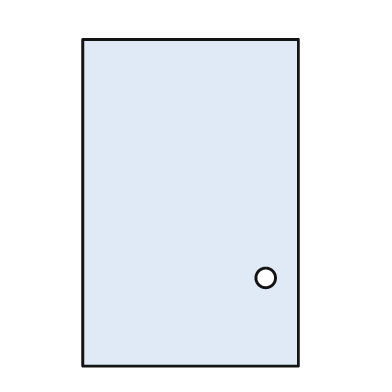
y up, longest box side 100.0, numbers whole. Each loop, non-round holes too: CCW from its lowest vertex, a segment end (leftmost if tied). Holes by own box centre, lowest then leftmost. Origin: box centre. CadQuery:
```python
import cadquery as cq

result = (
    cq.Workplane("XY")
    .moveTo(-33.0, -50.0)
    .lineTo(33.0, -50.0)
    .lineTo(33.0, 50.0)
    .lineTo(-33.0, 50.0)
    .close()
    .moveTo(23.0, -23.0)
    .circle(3.0)
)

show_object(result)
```